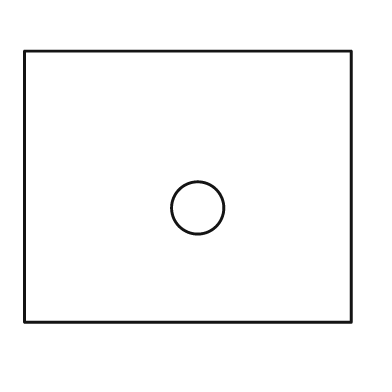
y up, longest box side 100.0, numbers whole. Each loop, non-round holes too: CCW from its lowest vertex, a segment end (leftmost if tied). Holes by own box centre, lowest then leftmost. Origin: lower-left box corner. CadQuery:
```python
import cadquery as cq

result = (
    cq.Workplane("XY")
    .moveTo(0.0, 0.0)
    .lineTo(100.0, 0.0)
    .lineTo(100.0, 83.0)
    .lineTo(0.0, 83.0)
    .close()
    .moveTo(53.0, 35.0)
    .circle(8.0)
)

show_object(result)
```